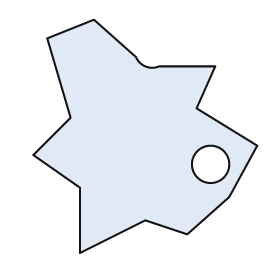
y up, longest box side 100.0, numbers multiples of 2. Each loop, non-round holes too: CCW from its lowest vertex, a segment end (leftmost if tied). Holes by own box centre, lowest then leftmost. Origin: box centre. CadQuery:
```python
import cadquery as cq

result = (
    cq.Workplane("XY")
    .moveTo(-28.0, -50.0)
    .lineTo(0.0, -36.0)
    .lineTo(18.0, -42.0)
    .lineTo(36.0, -26.0)
    .lineTo(48.0, -4.0)
    .lineTo(22.0, 12.0)
    .lineTo(30.0, 30.0)
    .lineTo(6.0, 30.0)
    .threePointArc((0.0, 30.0), (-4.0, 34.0))
    .lineTo(-22.0, 50.0)
    .lineTo(-42.0, 42.0)
    .lineTo(-32.0, 8.0)
    .lineTo(-48.0, -8.0)
    .lineTo(-28.0, -22.0)
    .close()
    .moveTo(28.0, -12.0)
    .circle(8.0)
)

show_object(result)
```